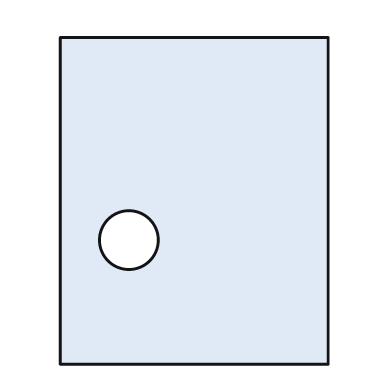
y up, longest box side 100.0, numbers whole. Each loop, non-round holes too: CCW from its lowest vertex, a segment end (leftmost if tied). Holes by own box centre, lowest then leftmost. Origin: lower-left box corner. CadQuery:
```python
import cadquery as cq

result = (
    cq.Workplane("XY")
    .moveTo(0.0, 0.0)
    .lineTo(82.0, 0.0)
    .lineTo(82.0, 100.0)
    .lineTo(0.0, 100.0)
    .close()
    .moveTo(21.0, 38.0)
    .circle(9.0)
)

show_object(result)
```